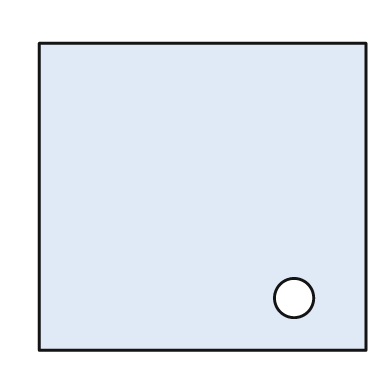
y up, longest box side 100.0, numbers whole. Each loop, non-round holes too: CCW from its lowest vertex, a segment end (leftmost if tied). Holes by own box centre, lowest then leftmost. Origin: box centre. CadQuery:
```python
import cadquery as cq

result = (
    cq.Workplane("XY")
    .moveTo(-50.0, -47.0)
    .lineTo(50.0, -47.0)
    .lineTo(50.0, 47.0)
    .lineTo(-50.0, 47.0)
    .close()
    .moveTo(28.0, -31.0)
    .circle(6.0)
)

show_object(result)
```